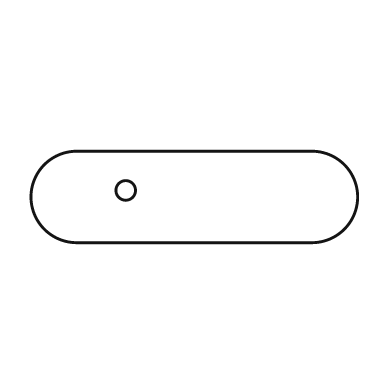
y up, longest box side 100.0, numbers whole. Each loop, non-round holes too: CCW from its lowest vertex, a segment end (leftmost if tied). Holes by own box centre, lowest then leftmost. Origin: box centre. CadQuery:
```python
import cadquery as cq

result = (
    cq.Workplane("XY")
    .moveTo(-36.0, -14.0)
    .lineTo(36.0, -14.0)
    .threePointArc((50.0, 0.0), (36.0, 14.0))
    .lineTo(-36.0, 14.0)
    .threePointArc((-50.0, 0.0), (-36.0, -14.0))
    .close()
    .moveTo(-21.0, 2.0)
    .circle(3.0)
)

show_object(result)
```